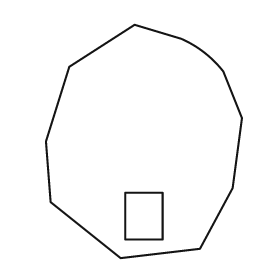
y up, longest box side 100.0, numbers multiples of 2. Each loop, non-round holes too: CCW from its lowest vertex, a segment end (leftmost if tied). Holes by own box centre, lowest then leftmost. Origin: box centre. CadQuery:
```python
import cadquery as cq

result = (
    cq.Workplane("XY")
    .moveTo(-10.0, -50.0)
    .lineTo(24.0, -46.0)
    .lineTo(38.0, -20.0)
    .lineTo(42.0, 10.0)
    .lineTo(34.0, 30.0)
    .threePointArc((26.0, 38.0), (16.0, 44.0))
    .lineTo(-4.0, 50.0)
    .lineTo(-32.0, 32.0)
    .lineTo(-42.0, 0.0)
    .lineTo(-40.0, -26.0)
    .close()
    .moveTo(-8.0, -42.0)
    .lineTo(8.0, -42.0)
    .lineTo(8.0, -22.0)
    .lineTo(-8.0, -22.0)
    .close()
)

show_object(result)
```